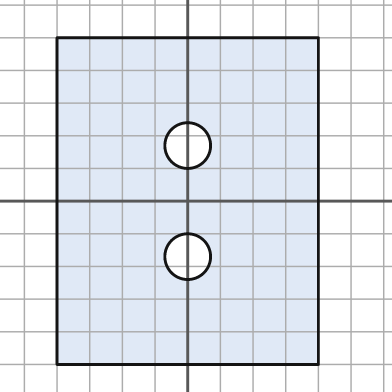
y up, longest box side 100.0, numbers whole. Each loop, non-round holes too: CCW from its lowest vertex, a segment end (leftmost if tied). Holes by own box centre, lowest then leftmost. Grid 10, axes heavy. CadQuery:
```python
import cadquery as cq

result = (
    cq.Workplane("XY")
    .moveTo(-40.0, -50.0)
    .lineTo(40.0, -50.0)
    .lineTo(40.0, 50.0)
    .lineTo(-40.0, 50.0)
    .close()
    .moveTo(0.0, -17.0)
    .circle(7.0)
    .moveTo(0.0, 17.0)
    .circle(7.0)
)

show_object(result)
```